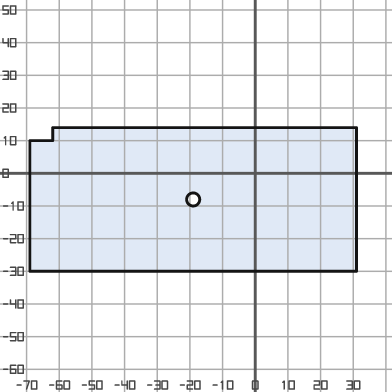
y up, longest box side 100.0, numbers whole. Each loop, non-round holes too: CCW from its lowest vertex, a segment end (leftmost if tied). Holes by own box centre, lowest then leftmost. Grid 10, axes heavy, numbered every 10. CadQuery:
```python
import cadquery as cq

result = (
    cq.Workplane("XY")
    .moveTo(-69.0, -30.0)
    .lineTo(31.0, -30.0)
    .lineTo(31.0, 14.0)
    .lineTo(-62.0, 14.0)
    .lineTo(-62.0, 10.0)
    .lineTo(-69.0, 10.0)
    .close()
    .moveTo(-19.0, -8.0)
    .circle(2.0)
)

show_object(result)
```